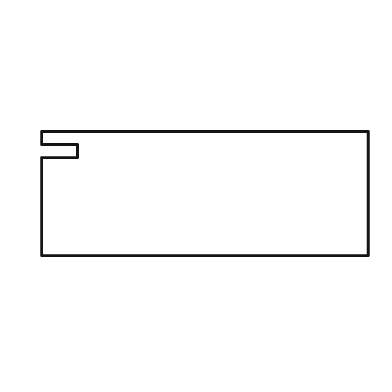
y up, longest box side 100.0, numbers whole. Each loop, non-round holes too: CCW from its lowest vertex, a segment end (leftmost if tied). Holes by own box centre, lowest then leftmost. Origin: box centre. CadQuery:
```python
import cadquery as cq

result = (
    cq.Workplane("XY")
    .moveTo(-50.0, -19.0)
    .lineTo(50.0, -19.0)
    .lineTo(50.0, 19.0)
    .lineTo(-50.0, 19.0)
    .lineTo(-50.0, 15.0)
    .lineTo(-39.0, 15.0)
    .lineTo(-39.0, 11.0)
    .lineTo(-50.0, 11.0)
    .close()
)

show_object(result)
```